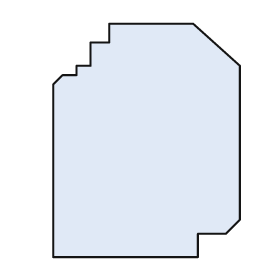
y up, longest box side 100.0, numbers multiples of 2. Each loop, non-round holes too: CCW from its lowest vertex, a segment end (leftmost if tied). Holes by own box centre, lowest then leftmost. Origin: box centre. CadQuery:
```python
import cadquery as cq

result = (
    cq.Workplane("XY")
    .moveTo(-40.0, -50.0)
    .lineTo(22.0, -50.0)
    .lineTo(22.0, -40.0)
    .lineTo(34.0, -40.0)
    .lineTo(40.0, -34.0)
    .lineTo(40.0, 32.0)
    .lineTo(20.0, 50.0)
    .lineTo(-16.0, 50.0)
    .lineTo(-16.0, 42.0)
    .lineTo(-24.0, 42.0)
    .lineTo(-24.0, 32.0)
    .lineTo(-30.0, 32.0)
    .lineTo(-30.0, 28.0)
    .lineTo(-36.0, 28.0)
    .lineTo(-40.0, 24.0)
    .close()
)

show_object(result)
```